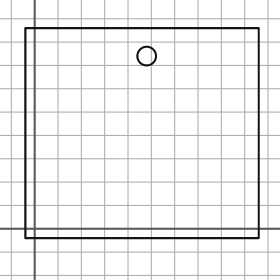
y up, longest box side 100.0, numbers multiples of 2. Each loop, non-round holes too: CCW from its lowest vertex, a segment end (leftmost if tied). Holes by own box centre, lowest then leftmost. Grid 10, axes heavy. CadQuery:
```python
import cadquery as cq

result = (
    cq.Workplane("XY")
    .moveTo(-4.0, -4.0)
    .lineTo(96.0, -4.0)
    .lineTo(96.0, 86.0)
    .lineTo(-4.0, 86.0)
    .close()
    .moveTo(48.0, 74.0)
    .circle(4.0)
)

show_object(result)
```